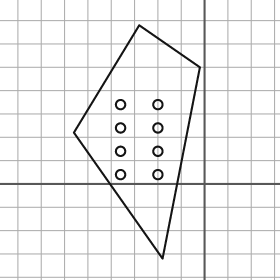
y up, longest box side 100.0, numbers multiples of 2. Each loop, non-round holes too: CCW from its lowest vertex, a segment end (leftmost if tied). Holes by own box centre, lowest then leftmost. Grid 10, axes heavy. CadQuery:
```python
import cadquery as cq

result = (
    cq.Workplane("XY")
    .moveTo(-18.0, -32.0)
    .lineTo(-2.0, 50.0)
    .lineTo(-28.0, 68.0)
    .lineTo(-56.0, 22.0)
    .close()
    .moveTo(-36.0, 4.0)
    .circle(2.0)
    .moveTo(-20.0, 4.0)
    .circle(2.0)
    .moveTo(-36.0, 14.0)
    .circle(2.0)
    .moveTo(-20.0, 14.0)
    .circle(2.0)
    .moveTo(-36.0, 24.0)
    .circle(2.0)
    .moveTo(-20.0, 24.0)
    .circle(2.0)
    .moveTo(-36.0, 34.0)
    .circle(2.0)
    .moveTo(-20.0, 34.0)
    .circle(2.0)
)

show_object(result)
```